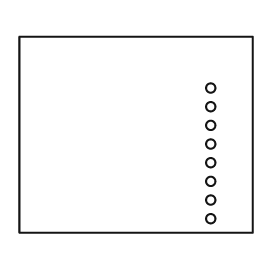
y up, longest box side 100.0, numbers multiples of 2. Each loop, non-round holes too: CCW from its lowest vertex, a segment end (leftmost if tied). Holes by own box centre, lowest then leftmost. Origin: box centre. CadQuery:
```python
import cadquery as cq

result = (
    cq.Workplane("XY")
    .moveTo(-50.0, -42.0)
    .lineTo(50.0, -42.0)
    .lineTo(50.0, 42.0)
    .lineTo(-50.0, 42.0)
    .close()
    .moveTo(32.0, -36.0)
    .circle(2.0)
    .moveTo(32.0, -28.0)
    .circle(2.0)
    .moveTo(32.0, -20.0)
    .circle(2.0)
    .moveTo(32.0, -12.0)
    .circle(2.0)
    .moveTo(32.0, -4.0)
    .circle(2.0)
    .moveTo(32.0, 4.0)
    .circle(2.0)
    .moveTo(32.0, 12.0)
    .circle(2.0)
    .moveTo(32.0, 20.0)
    .circle(2.0)
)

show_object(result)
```